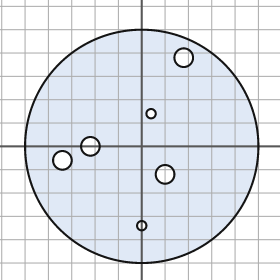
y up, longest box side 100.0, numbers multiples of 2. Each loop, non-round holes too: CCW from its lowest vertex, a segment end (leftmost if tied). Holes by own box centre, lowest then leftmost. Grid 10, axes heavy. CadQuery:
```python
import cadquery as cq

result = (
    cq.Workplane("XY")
    .moveTo(0.0, 0.0)
    .circle(50.0)
    .moveTo(0.0, -34.0)
    .circle(2.0)
    .moveTo(10.0, -12.0)
    .circle(4.0)
    .moveTo(-34.0, -6.0)
    .circle(4.0)
    .moveTo(-22.0, 0.0)
    .circle(4.0)
    .moveTo(4.0, 14.0)
    .circle(2.0)
    .moveTo(18.0, 38.0)
    .circle(4.0)
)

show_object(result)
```